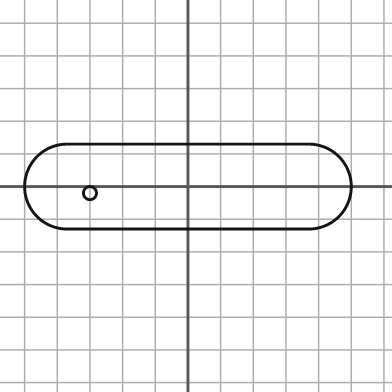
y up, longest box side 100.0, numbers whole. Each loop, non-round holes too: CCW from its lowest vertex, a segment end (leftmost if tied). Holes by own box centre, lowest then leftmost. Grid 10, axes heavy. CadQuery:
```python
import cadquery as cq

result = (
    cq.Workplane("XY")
    .moveTo(-37.0, -13.0)
    .lineTo(37.0, -13.0)
    .threePointArc((50.0, 0.0), (37.0, 13.0))
    .lineTo(-37.0, 13.0)
    .threePointArc((-50.0, 0.0), (-37.0, -13.0))
    .close()
    .moveTo(-30.0, -2.0)
    .circle(2.0)
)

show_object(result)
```